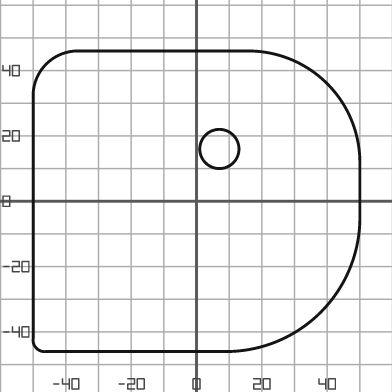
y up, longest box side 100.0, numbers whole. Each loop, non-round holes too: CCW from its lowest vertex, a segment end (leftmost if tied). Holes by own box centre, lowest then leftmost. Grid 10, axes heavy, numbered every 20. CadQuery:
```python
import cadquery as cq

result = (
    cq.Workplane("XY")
    .moveTo(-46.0, -46.0)
    .lineTo(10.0, -46.0)
    .threePointArc((38.0, -34.0), (50.0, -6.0))
    .lineTo(50.0, 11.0)
    .threePointArc((40.0, 36.0), (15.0, 46.0))
    .lineTo(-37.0, 46.0)
    .threePointArc((-46.0, 42.0), (-50.0, 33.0))
    .lineTo(-50.0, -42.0)
    .threePointArc((-49.0, -45.0), (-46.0, -46.0))
    .close()
    .moveTo(7.0, 16.0)
    .circle(6.0)
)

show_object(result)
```